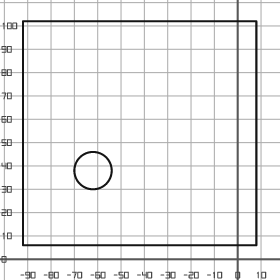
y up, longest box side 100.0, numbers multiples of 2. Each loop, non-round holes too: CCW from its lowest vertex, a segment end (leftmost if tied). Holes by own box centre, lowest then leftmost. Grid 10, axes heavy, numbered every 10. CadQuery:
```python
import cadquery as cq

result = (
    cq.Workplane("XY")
    .moveTo(-92.0, 6.0)
    .lineTo(8.0, 6.0)
    .lineTo(8.0, 102.0)
    .lineTo(-92.0, 102.0)
    .close()
    .moveTo(-62.0, 38.0)
    .circle(8.0)
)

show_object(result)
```